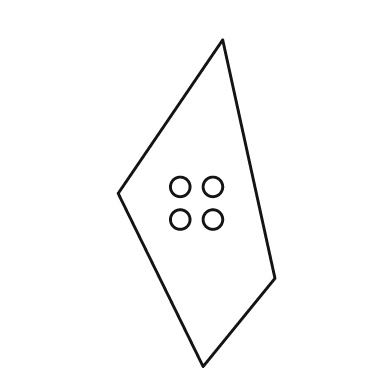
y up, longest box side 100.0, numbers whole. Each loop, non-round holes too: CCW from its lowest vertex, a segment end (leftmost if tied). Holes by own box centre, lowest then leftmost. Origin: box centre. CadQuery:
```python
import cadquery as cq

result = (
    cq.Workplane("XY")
    .moveTo(2.0, -50.0)
    .lineTo(24.0, -23.0)
    .lineTo(8.0, 50.0)
    .lineTo(-24.0, 3.0)
    .close()
    .moveTo(-5.0, -5.0)
    .circle(3.0)
    .moveTo(5.0, -5.0)
    .circle(3.0)
    .moveTo(-5.0, 5.0)
    .circle(3.0)
    .moveTo(5.0, 5.0)
    .circle(3.0)
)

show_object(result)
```